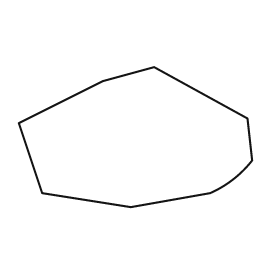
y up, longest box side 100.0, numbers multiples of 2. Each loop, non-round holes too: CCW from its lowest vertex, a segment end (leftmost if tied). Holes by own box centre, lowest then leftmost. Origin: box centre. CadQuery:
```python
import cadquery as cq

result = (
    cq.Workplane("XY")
    .moveTo(-2.0, -30.0)
    .lineTo(32.0, -24.0)
    .threePointArc((42.0, -18.0), (50.0, -10.0))
    .lineTo(48.0, 8.0)
    .lineTo(8.0, 30.0)
    .lineTo(-14.0, 24.0)
    .lineTo(-50.0, 6.0)
    .lineTo(-40.0, -24.0)
    .close()
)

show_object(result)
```